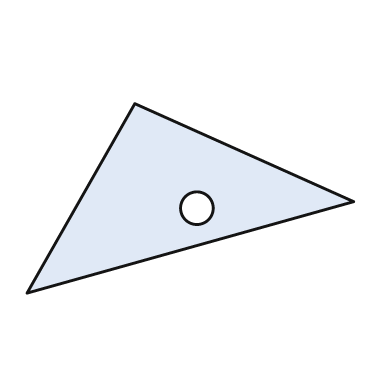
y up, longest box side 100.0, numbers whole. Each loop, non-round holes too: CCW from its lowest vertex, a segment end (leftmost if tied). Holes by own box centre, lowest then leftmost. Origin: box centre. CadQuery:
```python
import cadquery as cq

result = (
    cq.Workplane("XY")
    .moveTo(-50.0, -29.0)
    .lineTo(50.0, -1.0)
    .lineTo(-17.0, 29.0)
    .close()
    .moveTo(2.0, -3.0)
    .circle(5.0)
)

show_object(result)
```